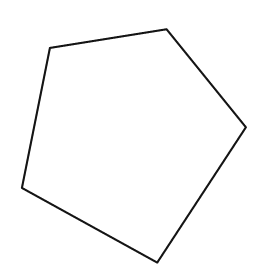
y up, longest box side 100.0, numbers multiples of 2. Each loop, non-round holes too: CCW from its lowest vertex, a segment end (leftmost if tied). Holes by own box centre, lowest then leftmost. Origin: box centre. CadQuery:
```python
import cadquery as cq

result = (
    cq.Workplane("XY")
    .moveTo(10.0, -50.0)
    .lineTo(48.0, 8.0)
    .lineTo(14.0, 50.0)
    .lineTo(-36.0, 42.0)
    .lineTo(-48.0, -18.0)
    .close()
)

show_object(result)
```